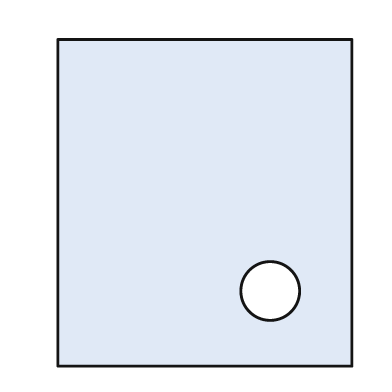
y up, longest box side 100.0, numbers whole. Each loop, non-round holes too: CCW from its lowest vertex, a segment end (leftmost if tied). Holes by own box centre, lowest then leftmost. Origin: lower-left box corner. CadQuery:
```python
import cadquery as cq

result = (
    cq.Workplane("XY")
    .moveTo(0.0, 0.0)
    .lineTo(90.0, 0.0)
    .lineTo(90.0, 100.0)
    .lineTo(0.0, 100.0)
    .close()
    .moveTo(65.0, 23.0)
    .circle(9.0)
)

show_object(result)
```